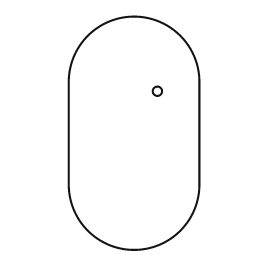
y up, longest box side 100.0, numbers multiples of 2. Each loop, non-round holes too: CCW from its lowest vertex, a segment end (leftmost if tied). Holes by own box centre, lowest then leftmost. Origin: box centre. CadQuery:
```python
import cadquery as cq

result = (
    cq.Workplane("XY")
    .moveTo(-28.0, -22.0)
    .threePointArc((0.0, -50.0), (28.0, -22.0))
    .lineTo(28.0, 22.0)
    .threePointArc((0.0, 50.0), (-28.0, 22.0))
    .close()
    .moveTo(10.0, 18.0)
    .circle(2.0)
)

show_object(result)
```